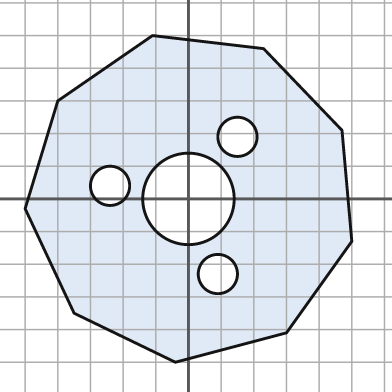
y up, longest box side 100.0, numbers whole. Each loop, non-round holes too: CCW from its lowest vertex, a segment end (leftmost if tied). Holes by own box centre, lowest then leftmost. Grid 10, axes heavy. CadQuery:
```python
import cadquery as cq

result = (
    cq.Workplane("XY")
    .moveTo(-4.0, -50.0)
    .lineTo(30.0, -41.0)
    .lineTo(50.0, -13.0)
    .lineTo(47.0, 21.0)
    .lineTo(23.0, 46.0)
    .lineTo(-11.0, 50.0)
    .lineTo(-40.0, 30.0)
    .lineTo(-50.0, -3.0)
    .lineTo(-35.0, -35.0)
    .close()
    .moveTo(9.0, -23.0)
    .circle(6.0)
    .moveTo(0.0, 0.0)
    .circle(14.0)
    .moveTo(-24.0, 4.0)
    .circle(6.0)
    .moveTo(15.0, 19.0)
    .circle(6.0)
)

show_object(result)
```